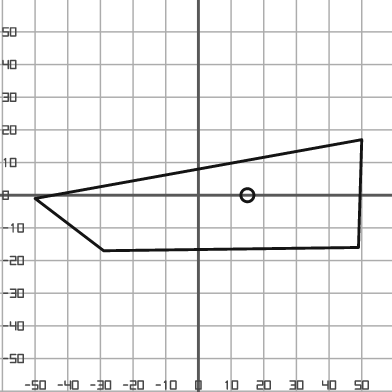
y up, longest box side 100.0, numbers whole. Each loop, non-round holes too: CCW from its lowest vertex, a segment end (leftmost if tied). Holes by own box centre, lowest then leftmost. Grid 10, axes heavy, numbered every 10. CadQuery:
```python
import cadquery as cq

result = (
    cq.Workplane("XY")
    .moveTo(-29.0, -17.0)
    .lineTo(49.0, -16.0)
    .lineTo(50.0, 17.0)
    .lineTo(-50.0, -1.0)
    .close()
    .moveTo(15.0, 0.0)
    .circle(2.0)
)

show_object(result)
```